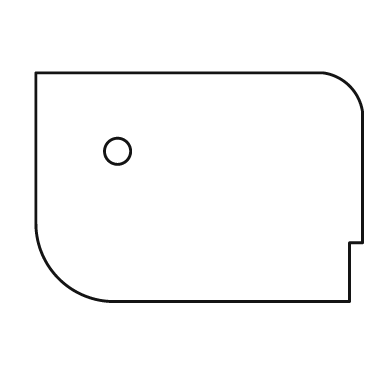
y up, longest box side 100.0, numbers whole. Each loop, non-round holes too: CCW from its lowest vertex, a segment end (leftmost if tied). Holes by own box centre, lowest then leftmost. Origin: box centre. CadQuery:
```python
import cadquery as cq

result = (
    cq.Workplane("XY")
    .moveTo(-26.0, -35.0)
    .lineTo(46.0, -35.0)
    .lineTo(46.0, -17.0)
    .lineTo(50.0, -17.0)
    .lineTo(50.0, 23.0)
    .threePointArc((46.0, 31.0), (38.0, 35.0))
    .lineTo(-50.0, 35.0)
    .lineTo(-50.0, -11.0)
    .threePointArc((-43.0, -28.0), (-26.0, -35.0))
    .close()
    .moveTo(-25.0, 11.0)
    .circle(4.0)
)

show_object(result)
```